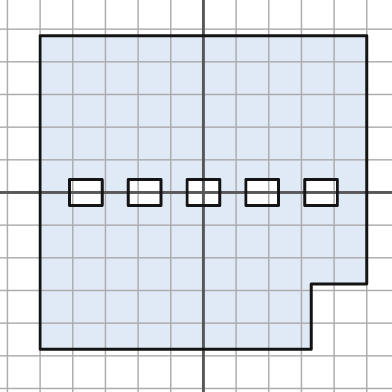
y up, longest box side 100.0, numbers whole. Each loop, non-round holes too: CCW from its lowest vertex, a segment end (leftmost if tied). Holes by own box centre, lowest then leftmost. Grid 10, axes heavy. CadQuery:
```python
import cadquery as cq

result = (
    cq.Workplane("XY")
    .moveTo(-50.0, -48.0)
    .lineTo(33.0, -48.0)
    .lineTo(33.0, -28.0)
    .lineTo(50.0, -28.0)
    .lineTo(50.0, 48.0)
    .lineTo(-50.0, 48.0)
    .close()
    .moveTo(-41.0, -4.0)
    .lineTo(-31.0, -4.0)
    .lineTo(-31.0, 4.0)
    .lineTo(-41.0, 4.0)
    .close()
    .moveTo(-23.0, -4.0)
    .lineTo(-13.0, -4.0)
    .lineTo(-13.0, 4.0)
    .lineTo(-23.0, 4.0)
    .close()
    .moveTo(-5.0, -4.0)
    .lineTo(5.0, -4.0)
    .lineTo(5.0, 4.0)
    .lineTo(-5.0, 4.0)
    .close()
    .moveTo(13.0, -4.0)
    .lineTo(23.0, -4.0)
    .lineTo(23.0, 4.0)
    .lineTo(13.0, 4.0)
    .close()
    .moveTo(31.0, -4.0)
    .lineTo(41.0, -4.0)
    .lineTo(41.0, 4.0)
    .lineTo(31.0, 4.0)
    .close()
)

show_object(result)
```